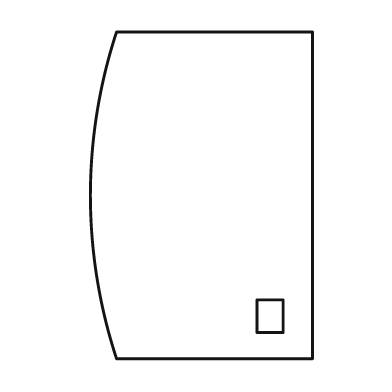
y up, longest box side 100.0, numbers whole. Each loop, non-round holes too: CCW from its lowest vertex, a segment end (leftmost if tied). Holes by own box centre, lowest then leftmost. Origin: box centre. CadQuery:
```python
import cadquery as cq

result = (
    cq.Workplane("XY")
    .moveTo(-26.0, -50.0)
    .lineTo(34.0, -50.0)
    .lineTo(34.0, 50.0)
    .lineTo(-26.0, 50.0)
    .threePointArc((-34.0, 0.0), (-26.0, -50.0))
    .close()
    .moveTo(17.0, -42.0)
    .lineTo(25.0, -42.0)
    .lineTo(25.0, -32.0)
    .lineTo(17.0, -32.0)
    .close()
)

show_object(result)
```